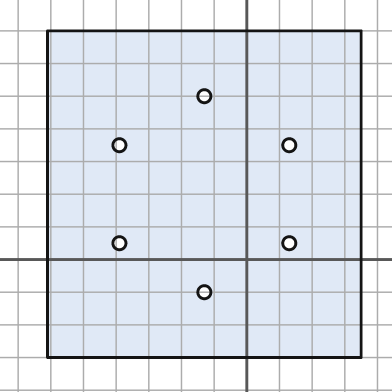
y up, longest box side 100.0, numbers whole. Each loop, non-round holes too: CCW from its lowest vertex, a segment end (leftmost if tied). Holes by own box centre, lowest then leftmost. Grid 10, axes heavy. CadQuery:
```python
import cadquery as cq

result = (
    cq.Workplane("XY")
    .moveTo(-61.0, -30.0)
    .lineTo(35.0, -30.0)
    .lineTo(35.0, 70.0)
    .lineTo(-61.0, 70.0)
    .close()
    .moveTo(-13.0, -10.0)
    .circle(2.0)
    .moveTo(-39.0, 5.0)
    .circle(2.0)
    .moveTo(13.0, 5.0)
    .circle(2.0)
    .moveTo(-39.0, 35.0)
    .circle(2.0)
    .moveTo(13.0, 35.0)
    .circle(2.0)
    .moveTo(-13.0, 50.0)
    .circle(2.0)
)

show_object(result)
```